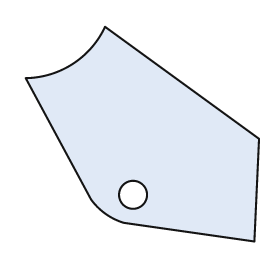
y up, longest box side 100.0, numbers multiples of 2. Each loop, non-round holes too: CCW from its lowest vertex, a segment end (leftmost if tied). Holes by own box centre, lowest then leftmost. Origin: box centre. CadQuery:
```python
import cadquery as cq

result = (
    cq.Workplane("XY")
    .moveTo(48.0, -46.0)
    .lineTo(50.0, -2.0)
    .lineTo(-16.0, 46.0)
    .threePointArc((-30.0, 30.0), (-50.0, 24.0))
    .lineTo(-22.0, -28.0)
    .threePointArc((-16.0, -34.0), (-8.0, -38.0))
    .close()
    .moveTo(-4.0, -26.0)
    .circle(6.0)
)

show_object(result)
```